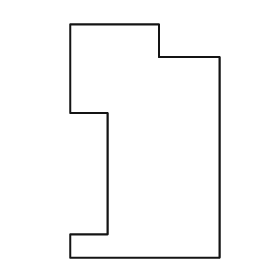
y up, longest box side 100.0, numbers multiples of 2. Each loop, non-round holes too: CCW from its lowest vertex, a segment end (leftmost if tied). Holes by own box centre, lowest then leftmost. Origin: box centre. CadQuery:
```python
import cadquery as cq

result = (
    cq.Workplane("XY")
    .moveTo(-32.0, -50.0)
    .lineTo(32.0, -50.0)
    .lineTo(32.0, 36.0)
    .lineTo(6.0, 36.0)
    .lineTo(6.0, 50.0)
    .lineTo(-32.0, 50.0)
    .lineTo(-32.0, 12.0)
    .lineTo(-16.0, 12.0)
    .lineTo(-16.0, -40.0)
    .lineTo(-32.0, -40.0)
    .close()
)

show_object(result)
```